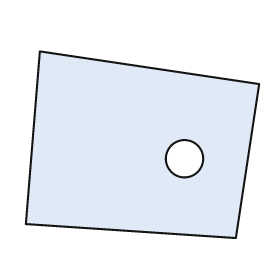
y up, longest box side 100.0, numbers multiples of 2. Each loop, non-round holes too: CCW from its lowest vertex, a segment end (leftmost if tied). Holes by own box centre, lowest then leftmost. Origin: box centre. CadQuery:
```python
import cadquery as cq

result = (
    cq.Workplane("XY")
    .moveTo(40.0, -40.0)
    .lineTo(50.0, 26.0)
    .lineTo(-44.0, 40.0)
    .lineTo(-50.0, -34.0)
    .close()
    .moveTo(18.0, -6.0)
    .circle(8.0)
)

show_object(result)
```